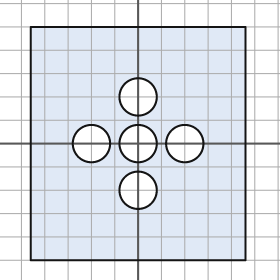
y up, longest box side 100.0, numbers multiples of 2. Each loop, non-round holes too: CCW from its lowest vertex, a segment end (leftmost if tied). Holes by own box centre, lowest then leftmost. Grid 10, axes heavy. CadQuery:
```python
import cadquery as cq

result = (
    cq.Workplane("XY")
    .moveTo(-46.0, -50.0)
    .lineTo(46.0, -50.0)
    .lineTo(46.0, 50.0)
    .lineTo(-46.0, 50.0)
    .close()
    .moveTo(0.0, -20.0)
    .circle(8.0)
    .moveTo(-20.0, 0.0)
    .circle(8.0)
    .moveTo(0.0, 0.0)
    .circle(8.0)
    .moveTo(20.0, 0.0)
    .circle(8.0)
    .moveTo(0.0, 20.0)
    .circle(8.0)
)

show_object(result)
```